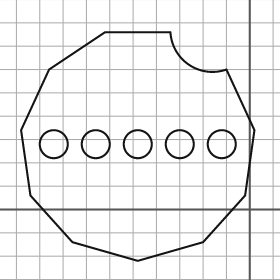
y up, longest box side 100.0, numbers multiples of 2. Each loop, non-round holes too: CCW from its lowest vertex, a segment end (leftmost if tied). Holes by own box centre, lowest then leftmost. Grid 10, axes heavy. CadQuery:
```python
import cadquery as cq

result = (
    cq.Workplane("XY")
    .moveTo(-48.0, -22.0)
    .lineTo(-20.0, -14.0)
    .lineTo(-2.0, 6.0)
    .lineTo(2.0, 34.0)
    .lineTo(-10.0, 60.0)
    .threePointArc((-26.0, 62.0), (-34.0, 76.0))
    .lineTo(-62.0, 76.0)
    .lineTo(-86.0, 60.0)
    .lineTo(-98.0, 34.0)
    .lineTo(-94.0, 6.0)
    .lineTo(-76.0, -14.0)
    .close()
    .moveTo(-84.0, 28.0)
    .circle(6.0)
    .moveTo(-66.0, 28.0)
    .circle(6.0)
    .moveTo(-48.0, 28.0)
    .circle(6.0)
    .moveTo(-30.0, 28.0)
    .circle(6.0)
    .moveTo(-12.0, 28.0)
    .circle(6.0)
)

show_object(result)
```